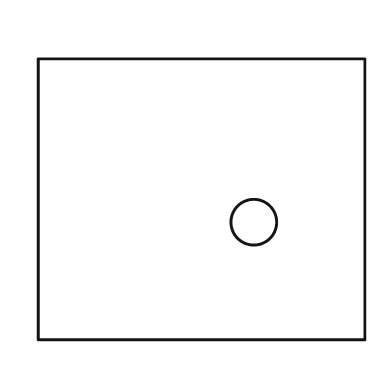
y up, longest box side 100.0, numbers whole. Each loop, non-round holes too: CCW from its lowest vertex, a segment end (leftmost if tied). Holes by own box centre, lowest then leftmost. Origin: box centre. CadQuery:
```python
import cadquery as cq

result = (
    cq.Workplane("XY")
    .moveTo(-50.0, -43.0)
    .lineTo(50.0, -43.0)
    .lineTo(50.0, 43.0)
    .lineTo(-50.0, 43.0)
    .close()
    .moveTo(16.0, -7.0)
    .circle(7.0)
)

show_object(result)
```